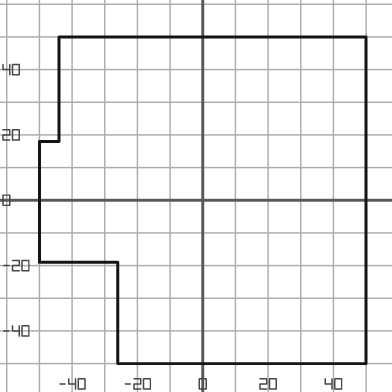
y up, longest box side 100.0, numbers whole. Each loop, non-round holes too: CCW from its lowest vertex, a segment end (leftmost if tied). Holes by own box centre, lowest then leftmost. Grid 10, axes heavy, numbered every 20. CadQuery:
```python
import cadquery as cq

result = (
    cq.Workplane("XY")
    .moveTo(-26.0, -50.0)
    .lineTo(50.0, -50.0)
    .lineTo(50.0, 50.0)
    .lineTo(-44.0, 50.0)
    .lineTo(-44.0, 18.0)
    .lineTo(-50.0, 18.0)
    .lineTo(-50.0, -19.0)
    .lineTo(-26.0, -19.0)
    .close()
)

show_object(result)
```